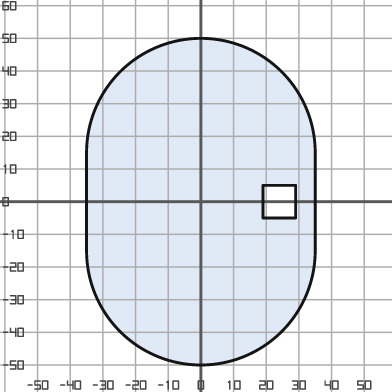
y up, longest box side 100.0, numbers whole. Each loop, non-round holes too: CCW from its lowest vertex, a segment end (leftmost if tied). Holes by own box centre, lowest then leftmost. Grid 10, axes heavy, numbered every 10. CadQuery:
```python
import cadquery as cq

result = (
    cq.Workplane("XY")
    .moveTo(-35.0, -15.0)
    .threePointArc((0.0, -50.0), (35.0, -15.0))
    .lineTo(35.0, 15.0)
    .threePointArc((0.0, 50.0), (-35.0, 15.0))
    .close()
    .moveTo(19.0, -5.0)
    .lineTo(29.0, -5.0)
    .lineTo(29.0, 5.0)
    .lineTo(19.0, 5.0)
    .close()
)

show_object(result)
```